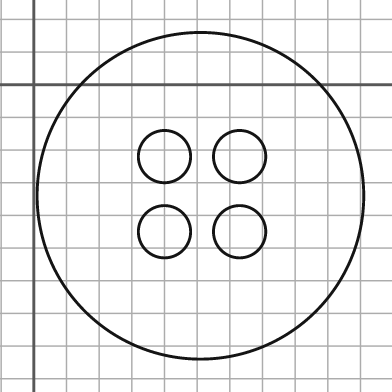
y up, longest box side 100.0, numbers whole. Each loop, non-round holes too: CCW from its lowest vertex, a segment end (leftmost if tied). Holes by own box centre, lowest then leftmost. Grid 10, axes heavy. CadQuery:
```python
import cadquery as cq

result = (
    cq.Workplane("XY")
    .moveTo(51.0, -34.0)
    .circle(50.0)
    .moveTo(40.0, -45.0)
    .circle(8.0)
    .moveTo(63.0, -45.0)
    .circle(8.0)
    .moveTo(40.0, -22.0)
    .circle(8.0)
    .moveTo(63.0, -22.0)
    .circle(8.0)
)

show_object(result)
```